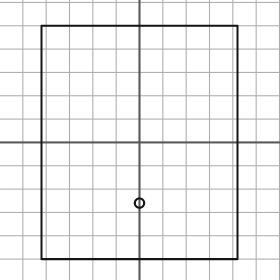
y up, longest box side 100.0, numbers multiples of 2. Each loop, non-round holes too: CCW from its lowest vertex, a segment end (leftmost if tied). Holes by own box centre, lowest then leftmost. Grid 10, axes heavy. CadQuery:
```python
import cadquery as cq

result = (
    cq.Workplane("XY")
    .moveTo(-42.0, -50.0)
    .lineTo(42.0, -50.0)
    .lineTo(42.0, 50.0)
    .lineTo(-42.0, 50.0)
    .close()
    .moveTo(0.0, -26.0)
    .circle(2.0)
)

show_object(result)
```